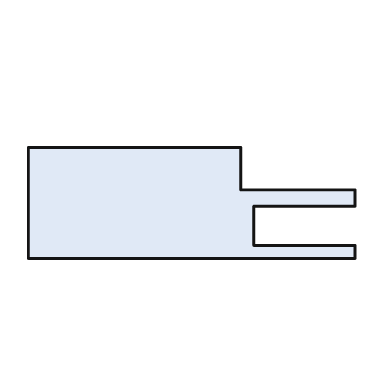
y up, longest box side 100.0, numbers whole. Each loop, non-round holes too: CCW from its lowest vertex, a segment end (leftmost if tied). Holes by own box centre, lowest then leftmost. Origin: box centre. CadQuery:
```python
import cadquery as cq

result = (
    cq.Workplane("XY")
    .moveTo(-50.0, -17.0)
    .lineTo(50.0, -17.0)
    .lineTo(50.0, -13.0)
    .lineTo(19.0, -13.0)
    .lineTo(19.0, -1.0)
    .lineTo(50.0, -1.0)
    .lineTo(50.0, 4.0)
    .lineTo(15.0, 4.0)
    .lineTo(15.0, 17.0)
    .lineTo(-50.0, 17.0)
    .close()
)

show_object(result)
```